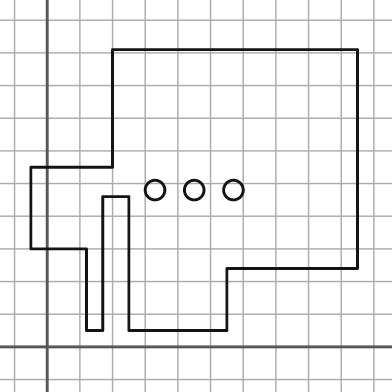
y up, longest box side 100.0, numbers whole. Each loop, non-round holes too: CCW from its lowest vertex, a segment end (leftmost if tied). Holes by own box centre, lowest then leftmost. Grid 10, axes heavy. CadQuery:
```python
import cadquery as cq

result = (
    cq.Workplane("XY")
    .moveTo(12.0, 5.0)
    .lineTo(17.0, 5.0)
    .lineTo(17.0, 46.0)
    .lineTo(25.0, 46.0)
    .lineTo(25.0, 5.0)
    .lineTo(55.0, 5.0)
    .lineTo(55.0, 24.0)
    .lineTo(95.0, 24.0)
    .lineTo(95.0, 91.0)
    .lineTo(20.0, 91.0)
    .lineTo(20.0, 55.0)
    .lineTo(-5.0, 55.0)
    .lineTo(-5.0, 30.0)
    .lineTo(12.0, 30.0)
    .close()
    .moveTo(33.0, 48.0)
    .circle(3.0)
    .moveTo(45.0, 48.0)
    .circle(3.0)
    .moveTo(57.0, 48.0)
    .circle(3.0)
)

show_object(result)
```